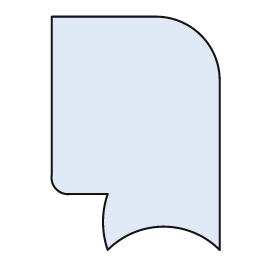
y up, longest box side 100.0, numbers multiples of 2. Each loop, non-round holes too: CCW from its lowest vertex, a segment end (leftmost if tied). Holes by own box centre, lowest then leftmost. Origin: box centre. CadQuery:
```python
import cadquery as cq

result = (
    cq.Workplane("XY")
    .moveTo(-12.0, -50.0)
    .threePointArc((12.0, -40.0), (36.0, -50.0))
    .lineTo(36.0, 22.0)
    .threePointArc((28.0, 42.0), (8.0, 50.0))
    .lineTo(-36.0, 50.0)
    .lineTo(-36.0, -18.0)
    .threePointArc((-34.0, -24.0), (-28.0, -26.0))
    .lineTo(-12.0, -26.0)
    .threePointArc((-14.0, -38.0), (-12.0, -50.0))
    .close()
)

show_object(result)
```